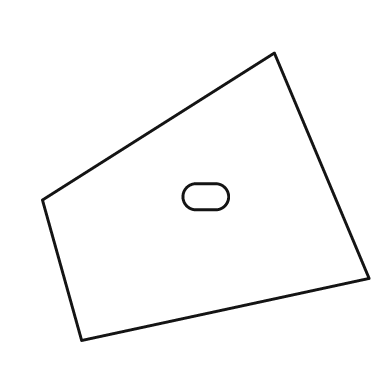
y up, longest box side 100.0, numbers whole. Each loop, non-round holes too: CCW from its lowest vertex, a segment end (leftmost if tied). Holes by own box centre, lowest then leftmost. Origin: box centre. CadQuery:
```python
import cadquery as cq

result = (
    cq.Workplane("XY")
    .moveTo(-38.0, -44.0)
    .lineTo(50.0, -25.0)
    .lineTo(21.0, 44.0)
    .lineTo(-50.0, -1.0)
    .close()
    .moveTo(-3.0, -4.0)
    .lineTo(3.0, -4.0)
    .threePointArc((7.0, 0.0), (3.0, 4.0))
    .lineTo(-3.0, 4.0)
    .threePointArc((-7.0, 0.0), (-3.0, -4.0))
    .close()
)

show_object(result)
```